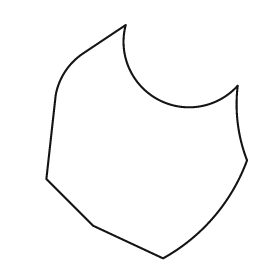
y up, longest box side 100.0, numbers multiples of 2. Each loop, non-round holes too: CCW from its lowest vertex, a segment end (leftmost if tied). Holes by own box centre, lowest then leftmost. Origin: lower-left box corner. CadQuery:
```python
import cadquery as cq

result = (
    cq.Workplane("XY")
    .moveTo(50.0, 0.0)
    .threePointArc((72.0, 18.0), (86.0, 42.0))
    .threePointArc((82.0, 58.0), (82.0, 74.0))
    .threePointArc((48.0, 68.0), (34.0, 100.0))
    .lineTo(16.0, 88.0)
    .threePointArc((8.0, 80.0), (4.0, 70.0))
    .lineTo(0.0, 34.0)
    .lineTo(20.0, 14.0)
    .close()
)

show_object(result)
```